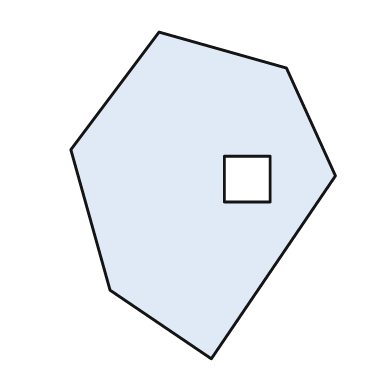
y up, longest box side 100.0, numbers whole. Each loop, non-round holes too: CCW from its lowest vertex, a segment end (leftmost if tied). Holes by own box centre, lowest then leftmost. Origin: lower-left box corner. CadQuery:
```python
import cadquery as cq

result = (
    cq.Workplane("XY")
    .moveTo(43.0, 0.0)
    .lineTo(81.0, 56.0)
    .lineTo(66.0, 89.0)
    .lineTo(27.0, 100.0)
    .lineTo(0.0, 64.0)
    .lineTo(12.0, 21.0)
    .close()
    .moveTo(47.0, 48.0)
    .lineTo(61.0, 48.0)
    .lineTo(61.0, 62.0)
    .lineTo(47.0, 62.0)
    .close()
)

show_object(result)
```